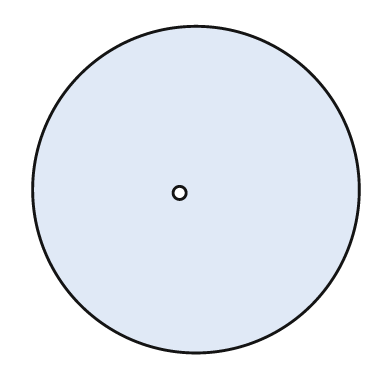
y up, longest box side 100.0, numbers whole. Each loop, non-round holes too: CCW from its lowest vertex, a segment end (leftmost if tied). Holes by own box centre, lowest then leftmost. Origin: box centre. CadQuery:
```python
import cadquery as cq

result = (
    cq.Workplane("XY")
    .moveTo(0.0, 0.0)
    .circle(50.0)
    .moveTo(-5.0, -1.0)
    .circle(2.0)
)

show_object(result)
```